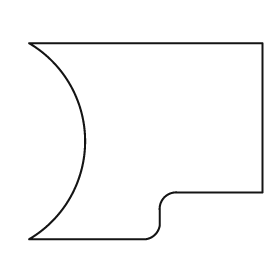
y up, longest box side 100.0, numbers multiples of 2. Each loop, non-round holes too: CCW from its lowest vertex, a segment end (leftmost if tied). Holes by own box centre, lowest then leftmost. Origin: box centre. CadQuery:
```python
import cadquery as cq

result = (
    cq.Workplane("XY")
    .moveTo(-50.0, -42.0)
    .lineTo(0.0, -42.0)
    .threePointArc((4.0, -40.0), (6.0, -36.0))
    .lineTo(6.0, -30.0)
    .threePointArc((8.0, -24.0), (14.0, -22.0))
    .lineTo(50.0, -22.0)
    .lineTo(50.0, 42.0)
    .lineTo(-50.0, 42.0)
    .threePointArc((-26.0, 0.0), (-50.0, -42.0))
    .close()
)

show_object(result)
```